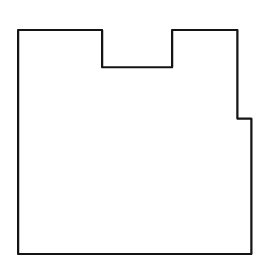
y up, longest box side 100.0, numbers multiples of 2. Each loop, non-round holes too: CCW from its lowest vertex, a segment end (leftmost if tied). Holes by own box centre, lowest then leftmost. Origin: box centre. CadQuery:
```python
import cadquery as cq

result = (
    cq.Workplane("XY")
    .moveTo(-50.0, -48.0)
    .lineTo(50.0, -48.0)
    .lineTo(50.0, 10.0)
    .lineTo(44.0, 10.0)
    .lineTo(44.0, 48.0)
    .lineTo(16.0, 48.0)
    .lineTo(16.0, 32.0)
    .lineTo(-14.0, 32.0)
    .lineTo(-14.0, 48.0)
    .lineTo(-50.0, 48.0)
    .close()
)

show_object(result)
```